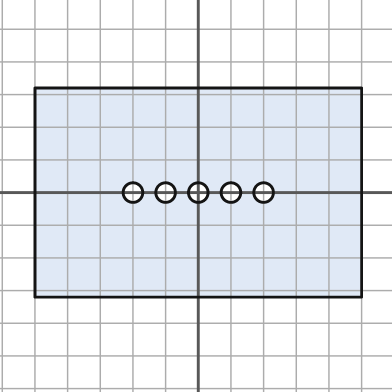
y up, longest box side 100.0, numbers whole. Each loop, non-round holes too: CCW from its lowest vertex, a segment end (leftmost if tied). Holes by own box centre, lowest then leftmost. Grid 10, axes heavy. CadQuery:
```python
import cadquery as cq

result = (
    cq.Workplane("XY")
    .moveTo(-50.0, -32.0)
    .lineTo(50.0, -32.0)
    .lineTo(50.0, 32.0)
    .lineTo(-50.0, 32.0)
    .close()
    .moveTo(-20.0, 0.0)
    .circle(3.0)
    .moveTo(-10.0, 0.0)
    .circle(3.0)
    .moveTo(0.0, 0.0)
    .circle(3.0)
    .moveTo(10.0, 0.0)
    .circle(3.0)
    .moveTo(20.0, 0.0)
    .circle(3.0)
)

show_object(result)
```